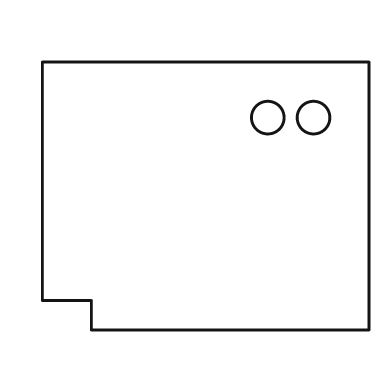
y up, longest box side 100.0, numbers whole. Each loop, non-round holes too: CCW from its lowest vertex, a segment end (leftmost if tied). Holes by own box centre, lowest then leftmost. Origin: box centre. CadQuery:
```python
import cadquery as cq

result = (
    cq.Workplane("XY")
    .moveTo(-35.0, -41.0)
    .lineTo(50.0, -41.0)
    .lineTo(50.0, 41.0)
    .lineTo(-50.0, 41.0)
    .lineTo(-50.0, -32.0)
    .lineTo(-35.0, -32.0)
    .close()
    .moveTo(19.0, 24.0)
    .circle(5.0)
    .moveTo(33.0, 24.0)
    .circle(5.0)
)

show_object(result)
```